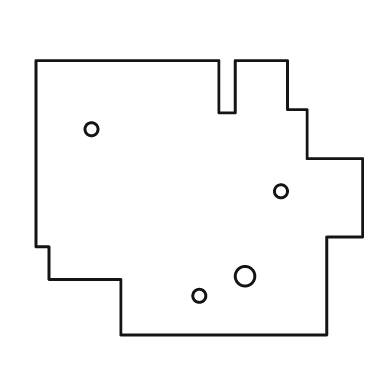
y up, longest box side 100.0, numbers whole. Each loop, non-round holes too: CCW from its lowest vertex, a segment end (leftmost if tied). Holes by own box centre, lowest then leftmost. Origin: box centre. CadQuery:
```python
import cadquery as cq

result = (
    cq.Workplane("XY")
    .moveTo(-24.0, -42.0)
    .lineTo(39.0, -42.0)
    .lineTo(39.0, -12.0)
    .lineTo(50.0, -12.0)
    .lineTo(50.0, 12.0)
    .lineTo(33.0, 12.0)
    .lineTo(33.0, 27.0)
    .lineTo(27.0, 27.0)
    .lineTo(27.0, 42.0)
    .lineTo(11.0, 42.0)
    .lineTo(11.0, 26.0)
    .lineTo(6.0, 26.0)
    .lineTo(6.0, 42.0)
    .lineTo(-50.0, 42.0)
    .lineTo(-50.0, -15.0)
    .lineTo(-46.0, -15.0)
    .lineTo(-46.0, -25.0)
    .lineTo(-24.0, -25.0)
    .close()
    .moveTo(0.0, -30.0)
    .circle(2.0)
    .moveTo(14.0, -24.0)
    .circle(3.0)
    .moveTo(25.0, 2.0)
    .circle(2.0)
    .moveTo(-33.0, 21.0)
    .circle(2.0)
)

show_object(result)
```